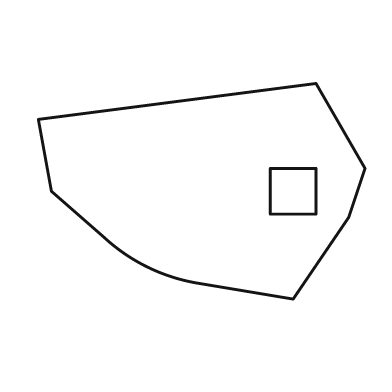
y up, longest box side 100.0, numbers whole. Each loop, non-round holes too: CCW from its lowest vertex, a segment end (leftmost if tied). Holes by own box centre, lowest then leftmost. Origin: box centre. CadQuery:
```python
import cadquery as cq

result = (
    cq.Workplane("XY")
    .moveTo(28.0, -33.0)
    .lineTo(45.0, -8.0)
    .lineTo(50.0, 7.0)
    .lineTo(35.0, 33.0)
    .lineTo(-50.0, 22.0)
    .lineTo(-46.0, 0.0)
    .lineTo(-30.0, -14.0)
    .threePointArc((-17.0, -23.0), (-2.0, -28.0))
    .close()
    .moveTo(21.0, -7.0)
    .lineTo(35.0, -7.0)
    .lineTo(35.0, 7.0)
    .lineTo(21.0, 7.0)
    .close()
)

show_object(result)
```